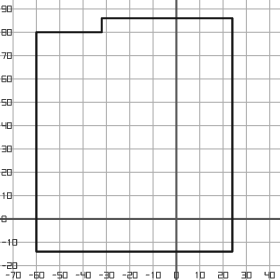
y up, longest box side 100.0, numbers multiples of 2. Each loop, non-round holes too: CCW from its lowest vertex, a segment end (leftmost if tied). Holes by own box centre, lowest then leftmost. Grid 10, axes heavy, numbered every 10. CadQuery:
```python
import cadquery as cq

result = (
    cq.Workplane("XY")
    .moveTo(-60.0, -14.0)
    .lineTo(24.0, -14.0)
    .lineTo(24.0, 86.0)
    .lineTo(-32.0, 86.0)
    .lineTo(-32.0, 80.0)
    .lineTo(-60.0, 80.0)
    .close()
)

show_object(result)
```